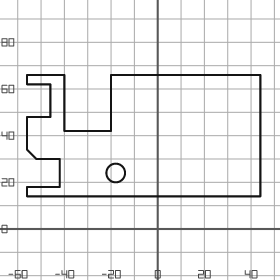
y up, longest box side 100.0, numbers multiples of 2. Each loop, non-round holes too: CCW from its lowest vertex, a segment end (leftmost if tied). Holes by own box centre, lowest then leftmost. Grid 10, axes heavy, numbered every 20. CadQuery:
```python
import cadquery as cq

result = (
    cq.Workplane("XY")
    .moveTo(-56.0, 14.0)
    .lineTo(44.0, 14.0)
    .lineTo(44.0, 66.0)
    .lineTo(-20.0, 66.0)
    .lineTo(-20.0, 42.0)
    .lineTo(-40.0, 42.0)
    .lineTo(-40.0, 66.0)
    .lineTo(-56.0, 66.0)
    .lineTo(-56.0, 62.0)
    .lineTo(-46.0, 62.0)
    .lineTo(-46.0, 48.0)
    .lineTo(-56.0, 48.0)
    .lineTo(-56.0, 34.0)
    .lineTo(-52.0, 30.0)
    .lineTo(-42.0, 30.0)
    .lineTo(-42.0, 18.0)
    .lineTo(-56.0, 18.0)
    .close()
    .moveTo(-18.0, 24.0)
    .circle(4.0)
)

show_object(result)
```